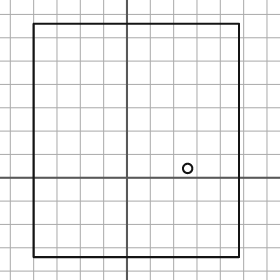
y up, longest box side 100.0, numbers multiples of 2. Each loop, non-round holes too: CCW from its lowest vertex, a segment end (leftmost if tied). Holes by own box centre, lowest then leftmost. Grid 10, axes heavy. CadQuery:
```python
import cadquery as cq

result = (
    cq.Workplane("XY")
    .moveTo(-40.0, -34.0)
    .lineTo(48.0, -34.0)
    .lineTo(48.0, 66.0)
    .lineTo(-40.0, 66.0)
    .close()
    .moveTo(26.0, 4.0)
    .circle(2.0)
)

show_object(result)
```